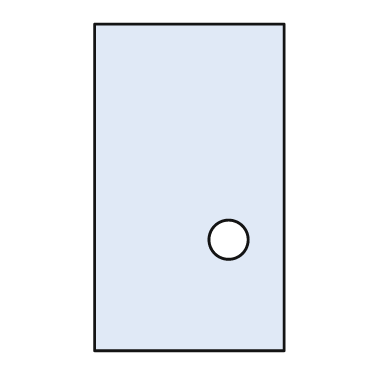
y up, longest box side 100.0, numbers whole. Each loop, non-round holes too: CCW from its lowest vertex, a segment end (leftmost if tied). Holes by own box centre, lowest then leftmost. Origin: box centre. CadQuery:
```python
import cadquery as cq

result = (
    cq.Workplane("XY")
    .moveTo(-29.0, -50.0)
    .lineTo(29.0, -50.0)
    .lineTo(29.0, 50.0)
    .lineTo(-29.0, 50.0)
    .close()
    .moveTo(12.0, -16.0)
    .circle(6.0)
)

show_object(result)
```